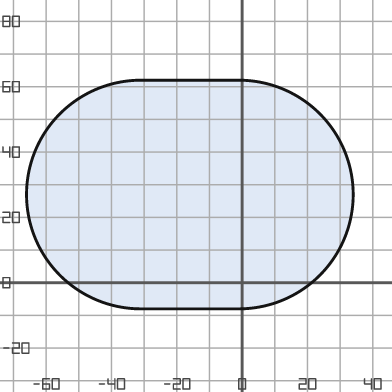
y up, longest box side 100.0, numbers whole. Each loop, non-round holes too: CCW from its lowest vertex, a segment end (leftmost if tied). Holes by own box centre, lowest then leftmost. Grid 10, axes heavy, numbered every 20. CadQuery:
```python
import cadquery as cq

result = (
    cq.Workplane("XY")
    .moveTo(-31.0, -8.0)
    .lineTo(-1.0, -8.0)
    .threePointArc((34.0, 27.0), (-1.0, 62.0))
    .lineTo(-31.0, 62.0)
    .threePointArc((-66.0, 27.0), (-31.0, -8.0))
    .close()
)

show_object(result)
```